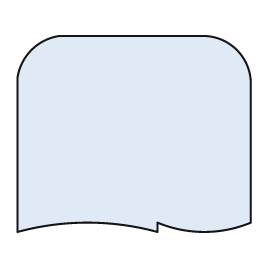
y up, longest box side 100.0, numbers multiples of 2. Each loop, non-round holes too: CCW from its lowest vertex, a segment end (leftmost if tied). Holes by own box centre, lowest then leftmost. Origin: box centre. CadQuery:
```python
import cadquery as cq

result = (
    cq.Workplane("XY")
    .moveTo(-50.0, -42.0)
    .threePointArc((-20.0, -38.0), (10.0, -42.0))
    .lineTo(10.0, -38.0)
    .threePointArc((30.0, -42.0), (50.0, -38.0))
    .lineTo(50.0, 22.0)
    .threePointArc((44.0, 36.0), (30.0, 42.0))
    .lineTo(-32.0, 42.0)
    .threePointArc((-44.0, 36.0), (-50.0, 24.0))
    .close()
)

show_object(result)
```